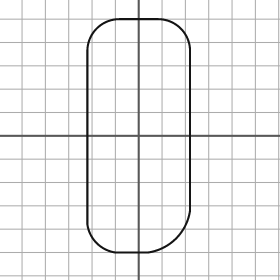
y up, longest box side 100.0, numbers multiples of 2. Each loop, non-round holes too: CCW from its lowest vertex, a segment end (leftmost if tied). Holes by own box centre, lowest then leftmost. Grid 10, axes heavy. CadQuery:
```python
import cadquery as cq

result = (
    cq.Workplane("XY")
    .moveTo(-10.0, -50.0)
    .lineTo(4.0, -50.0)
    .threePointArc((16.0, -44.0), (22.0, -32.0))
    .lineTo(22.0, 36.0)
    .threePointArc((18.0, 46.0), (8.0, 50.0))
    .lineTo(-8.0, 50.0)
    .threePointArc((-18.0, 46.0), (-22.0, 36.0))
    .lineTo(-22.0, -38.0)
    .threePointArc((-18.0, -46.0), (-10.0, -50.0))
    .close()
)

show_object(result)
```